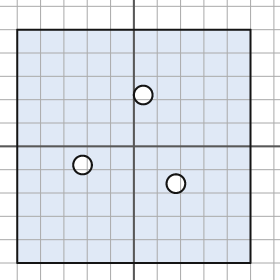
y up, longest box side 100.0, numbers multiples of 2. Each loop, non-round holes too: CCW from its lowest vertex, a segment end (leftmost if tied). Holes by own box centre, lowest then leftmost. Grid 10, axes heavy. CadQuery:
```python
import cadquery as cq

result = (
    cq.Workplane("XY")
    .moveTo(-50.0, -50.0)
    .lineTo(50.0, -50.0)
    .lineTo(50.0, 50.0)
    .lineTo(-50.0, 50.0)
    .close()
    .moveTo(18.0, -16.0)
    .circle(4.0)
    .moveTo(-22.0, -8.0)
    .circle(4.0)
    .moveTo(4.0, 22.0)
    .circle(4.0)
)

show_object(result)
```